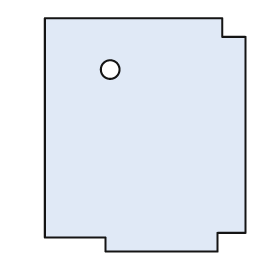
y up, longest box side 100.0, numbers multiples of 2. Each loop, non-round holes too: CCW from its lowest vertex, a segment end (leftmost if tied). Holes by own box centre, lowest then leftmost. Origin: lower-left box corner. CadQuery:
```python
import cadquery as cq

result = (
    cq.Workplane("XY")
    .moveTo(26.0, 0.0)
    .lineTo(74.0, 0.0)
    .lineTo(74.0, 8.0)
    .lineTo(86.0, 8.0)
    .lineTo(86.0, 92.0)
    .lineTo(76.0, 92.0)
    .lineTo(76.0, 100.0)
    .lineTo(0.0, 100.0)
    .lineTo(0.0, 6.0)
    .lineTo(26.0, 6.0)
    .close()
    .moveTo(28.0, 78.0)
    .circle(4.0)
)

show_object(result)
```